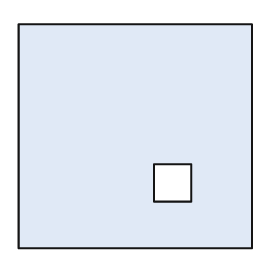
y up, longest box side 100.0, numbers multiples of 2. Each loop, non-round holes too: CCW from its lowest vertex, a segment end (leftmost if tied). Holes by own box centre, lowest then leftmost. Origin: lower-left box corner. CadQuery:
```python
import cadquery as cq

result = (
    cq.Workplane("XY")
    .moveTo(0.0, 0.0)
    .lineTo(100.0, 0.0)
    .lineTo(100.0, 96.0)
    .lineTo(0.0, 96.0)
    .close()
    .moveTo(58.0, 20.0)
    .lineTo(74.0, 20.0)
    .lineTo(74.0, 36.0)
    .lineTo(58.0, 36.0)
    .close()
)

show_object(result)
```